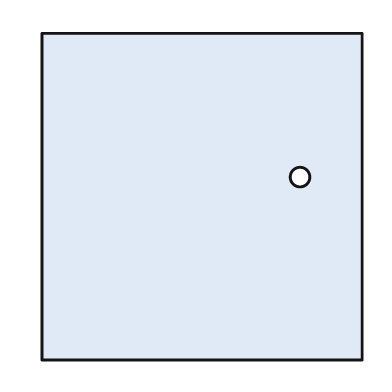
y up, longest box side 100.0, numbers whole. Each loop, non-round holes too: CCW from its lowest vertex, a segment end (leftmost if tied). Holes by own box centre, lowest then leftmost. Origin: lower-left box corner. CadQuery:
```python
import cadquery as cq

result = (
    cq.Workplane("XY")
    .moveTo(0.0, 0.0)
    .lineTo(98.0, 0.0)
    .lineTo(98.0, 100.0)
    .lineTo(0.0, 100.0)
    .close()
    .moveTo(79.0, 56.0)
    .circle(3.0)
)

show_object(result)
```